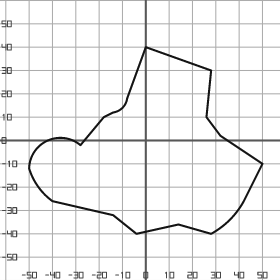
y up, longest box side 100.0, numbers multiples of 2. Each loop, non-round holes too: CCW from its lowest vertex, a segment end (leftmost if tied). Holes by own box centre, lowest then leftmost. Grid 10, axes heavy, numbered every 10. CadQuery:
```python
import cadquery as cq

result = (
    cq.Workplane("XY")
    .moveTo(-4.0, -40.0)
    .lineTo(14.0, -36.0)
    .lineTo(28.0, -40.0)
    .threePointArc((36.0, -34.0), (42.0, -26.0))
    .lineTo(50.0, -10.0)
    .lineTo(32.0, 2.0)
    .lineTo(26.0, 10.0)
    .lineTo(28.0, 30.0)
    .lineTo(0.0, 40.0)
    .lineTo(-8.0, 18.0)
    .threePointArc((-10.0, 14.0), (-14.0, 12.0))
    .lineTo(-18.0, 10.0)
    .lineTo(-28.0, -2.0)
    .threePointArc((-42.0, 0.0), (-50.0, -12.0))
    .threePointArc((-46.0, -20.0), (-40.0, -26.0))
    .lineTo(-14.0, -32.0)
    .close()
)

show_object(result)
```